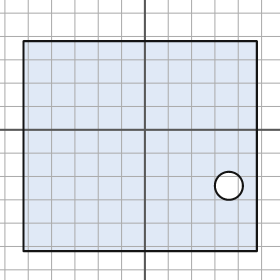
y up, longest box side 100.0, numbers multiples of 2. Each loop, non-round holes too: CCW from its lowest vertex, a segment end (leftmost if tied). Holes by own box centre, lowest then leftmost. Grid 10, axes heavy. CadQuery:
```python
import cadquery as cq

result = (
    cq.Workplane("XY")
    .moveTo(-52.0, -52.0)
    .lineTo(48.0, -52.0)
    .lineTo(48.0, 38.0)
    .lineTo(-52.0, 38.0)
    .close()
    .moveTo(36.0, -24.0)
    .circle(6.0)
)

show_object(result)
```